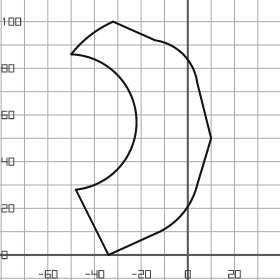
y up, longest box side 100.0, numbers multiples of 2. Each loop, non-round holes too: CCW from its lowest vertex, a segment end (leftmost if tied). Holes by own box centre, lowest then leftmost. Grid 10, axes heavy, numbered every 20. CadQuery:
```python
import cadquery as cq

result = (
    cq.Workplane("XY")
    .moveTo(-34.0, 0.0)
    .lineTo(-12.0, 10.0)
    .threePointArc((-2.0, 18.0), (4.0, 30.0))
    .lineTo(10.0, 50.0)
    .lineTo(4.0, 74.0)
    .threePointArc((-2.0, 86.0), (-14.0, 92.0))
    .lineTo(-32.0, 100.0)
    .threePointArc((-42.0, 94.0), (-50.0, 86.0))
    .threePointArc((-22.0, 58.0), (-48.0, 28.0))
    .close()
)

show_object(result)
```